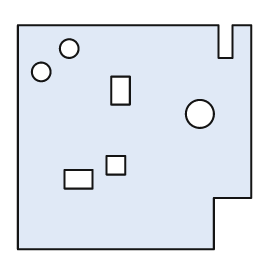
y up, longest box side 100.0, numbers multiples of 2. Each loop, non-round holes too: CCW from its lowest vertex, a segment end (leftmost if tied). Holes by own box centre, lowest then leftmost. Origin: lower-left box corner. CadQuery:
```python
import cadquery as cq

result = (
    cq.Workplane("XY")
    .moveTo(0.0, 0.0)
    .lineTo(84.0, 0.0)
    .lineTo(84.0, 22.0)
    .lineTo(100.0, 22.0)
    .lineTo(100.0, 96.0)
    .lineTo(92.0, 96.0)
    .lineTo(92.0, 82.0)
    .lineTo(86.0, 82.0)
    .lineTo(86.0, 96.0)
    .lineTo(0.0, 96.0)
    .close()
    .moveTo(20.0, 26.0)
    .lineTo(32.0, 26.0)
    .lineTo(32.0, 34.0)
    .lineTo(20.0, 34.0)
    .close()
    .moveTo(38.0, 32.0)
    .lineTo(46.0, 32.0)
    .lineTo(46.0, 40.0)
    .lineTo(38.0, 40.0)
    .close()
    .moveTo(78.0, 58.0)
    .circle(6.0)
    .moveTo(40.0, 62.0)
    .lineTo(48.0, 62.0)
    .lineTo(48.0, 74.0)
    .lineTo(40.0, 74.0)
    .close()
    .moveTo(10.0, 76.0)
    .circle(4.0)
    .moveTo(22.0, 86.0)
    .circle(4.0)
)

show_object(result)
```